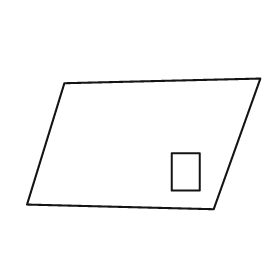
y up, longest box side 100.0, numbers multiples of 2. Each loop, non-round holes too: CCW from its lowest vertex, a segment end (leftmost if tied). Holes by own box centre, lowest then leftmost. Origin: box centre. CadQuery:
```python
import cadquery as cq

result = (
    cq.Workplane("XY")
    .moveTo(30.0, -28.0)
    .lineTo(50.0, 28.0)
    .lineTo(-34.0, 26.0)
    .lineTo(-50.0, -26.0)
    .close()
    .moveTo(12.0, -20.0)
    .lineTo(24.0, -20.0)
    .lineTo(24.0, -4.0)
    .lineTo(12.0, -4.0)
    .close()
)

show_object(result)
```